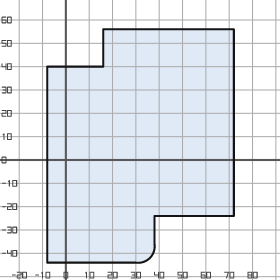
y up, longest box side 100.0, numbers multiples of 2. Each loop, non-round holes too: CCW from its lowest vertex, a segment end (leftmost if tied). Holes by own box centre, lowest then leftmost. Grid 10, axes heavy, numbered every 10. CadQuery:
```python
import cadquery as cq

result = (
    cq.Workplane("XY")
    .moveTo(-8.0, -44.0)
    .lineTo(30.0, -44.0)
    .threePointArc((36.0, -42.0), (38.0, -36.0))
    .lineTo(38.0, -24.0)
    .lineTo(72.0, -24.0)
    .lineTo(72.0, 56.0)
    .lineTo(16.0, 56.0)
    .lineTo(16.0, 40.0)
    .lineTo(-8.0, 40.0)
    .close()
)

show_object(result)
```